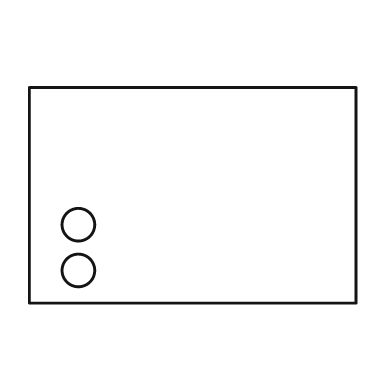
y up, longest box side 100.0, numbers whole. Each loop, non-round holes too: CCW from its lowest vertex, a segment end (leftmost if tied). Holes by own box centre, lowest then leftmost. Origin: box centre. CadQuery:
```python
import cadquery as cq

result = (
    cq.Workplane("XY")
    .moveTo(-50.0, -33.0)
    .lineTo(50.0, -33.0)
    .lineTo(50.0, 33.0)
    .lineTo(-50.0, 33.0)
    .close()
    .moveTo(-35.0, -23.0)
    .circle(5.0)
    .moveTo(-35.0, -9.0)
    .circle(5.0)
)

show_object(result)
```